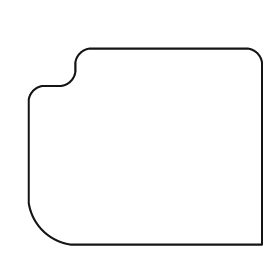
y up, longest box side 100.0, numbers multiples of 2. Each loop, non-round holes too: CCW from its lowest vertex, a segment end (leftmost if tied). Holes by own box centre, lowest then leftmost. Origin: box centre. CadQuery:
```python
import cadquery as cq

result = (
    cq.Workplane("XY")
    .moveTo(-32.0, -42.0)
    .lineTo(50.0, -42.0)
    .lineTo(50.0, 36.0)
    .threePointArc((48.0, 40.0), (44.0, 42.0))
    .lineTo(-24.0, 42.0)
    .threePointArc((-28.0, 40.0), (-30.0, 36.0))
    .lineTo(-30.0, 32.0)
    .threePointArc((-32.0, 28.0), (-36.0, 26.0))
    .lineTo(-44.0, 26.0)
    .threePointArc((-48.0, 24.0), (-50.0, 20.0))
    .lineTo(-50.0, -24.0)
    .threePointArc((-44.0, -36.0), (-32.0, -42.0))
    .close()
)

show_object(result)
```